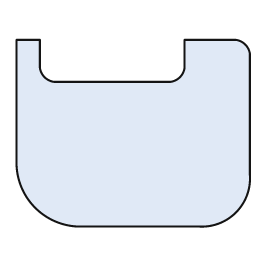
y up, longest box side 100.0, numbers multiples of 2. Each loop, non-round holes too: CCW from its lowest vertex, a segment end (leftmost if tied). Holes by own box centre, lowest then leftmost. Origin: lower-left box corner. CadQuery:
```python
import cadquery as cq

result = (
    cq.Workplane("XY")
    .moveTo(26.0, 0.0)
    .lineTo(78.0, 0.0)
    .threePointArc((94.0, 6.0), (100.0, 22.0))
    .lineTo(100.0, 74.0)
    .threePointArc((98.0, 78.0), (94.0, 80.0))
    .lineTo(72.0, 80.0)
    .lineTo(72.0, 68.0)
    .threePointArc((70.0, 64.0), (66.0, 62.0))
    .lineTo(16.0, 62.0)
    .threePointArc((12.0, 64.0), (10.0, 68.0))
    .lineTo(10.0, 80.0)
    .lineTo(0.0, 80.0)
    .lineTo(0.0, 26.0)
    .threePointArc((8.0, 8.0), (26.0, 0.0))
    .close()
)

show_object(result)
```